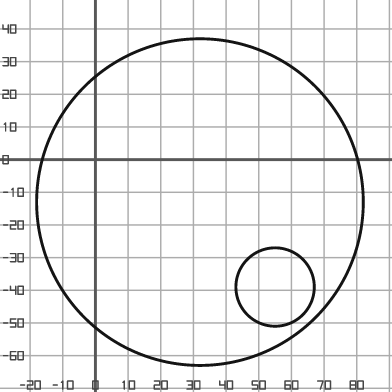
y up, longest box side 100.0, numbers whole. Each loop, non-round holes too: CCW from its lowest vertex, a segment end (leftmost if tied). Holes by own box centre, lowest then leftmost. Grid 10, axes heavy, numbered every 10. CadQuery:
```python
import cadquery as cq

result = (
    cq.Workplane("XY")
    .moveTo(32.0, -13.0)
    .circle(50.0)
    .moveTo(55.0, -39.0)
    .circle(12.0)
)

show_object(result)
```